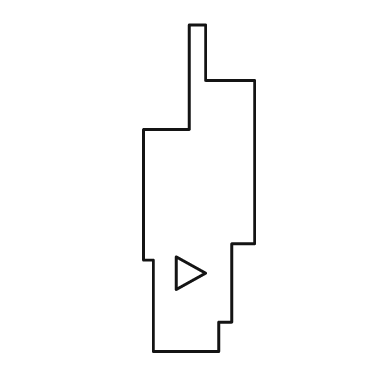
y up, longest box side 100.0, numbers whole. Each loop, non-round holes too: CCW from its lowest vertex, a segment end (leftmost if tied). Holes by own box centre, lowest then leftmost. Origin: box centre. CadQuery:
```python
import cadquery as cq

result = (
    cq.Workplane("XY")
    .moveTo(-14.0, -50.0)
    .lineTo(6.0, -50.0)
    .lineTo(6.0, -41.0)
    .lineTo(10.0, -41.0)
    .lineTo(10.0, -17.0)
    .lineTo(17.0, -17.0)
    .lineTo(17.0, 33.0)
    .lineTo(2.0, 33.0)
    .lineTo(2.0, 50.0)
    .lineTo(-3.0, 50.0)
    .lineTo(-3.0, 18.0)
    .lineTo(-17.0, 18.0)
    .lineTo(-17.0, -22.0)
    .lineTo(-14.0, -22.0)
    .close()
    .moveTo(-7.0, -31.0)
    .lineTo(2.0, -26.0)
    .lineTo(-7.0, -21.0)
    .close()
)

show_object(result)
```